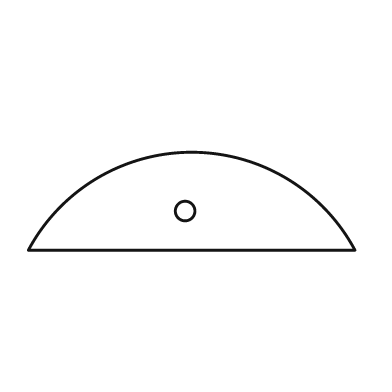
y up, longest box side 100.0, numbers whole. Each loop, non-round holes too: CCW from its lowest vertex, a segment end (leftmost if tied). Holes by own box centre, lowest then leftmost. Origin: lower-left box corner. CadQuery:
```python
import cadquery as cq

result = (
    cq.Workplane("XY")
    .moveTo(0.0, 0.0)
    .lineTo(100.0, 0.0)
    .threePointArc((50.0, 30.0), (0.0, 0.0))
    .close()
    .moveTo(48.0, 12.0)
    .circle(3.0)
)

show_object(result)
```